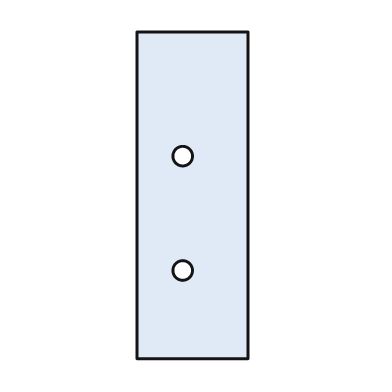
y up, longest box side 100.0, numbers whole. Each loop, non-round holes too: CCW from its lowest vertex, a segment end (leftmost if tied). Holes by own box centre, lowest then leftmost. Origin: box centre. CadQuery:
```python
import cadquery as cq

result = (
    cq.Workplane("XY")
    .moveTo(-17.0, -50.0)
    .lineTo(17.0, -50.0)
    .lineTo(17.0, 50.0)
    .lineTo(-17.0, 50.0)
    .close()
    .moveTo(-3.0, -23.0)
    .circle(3.0)
    .moveTo(-3.0, 12.0)
    .circle(3.0)
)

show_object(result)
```